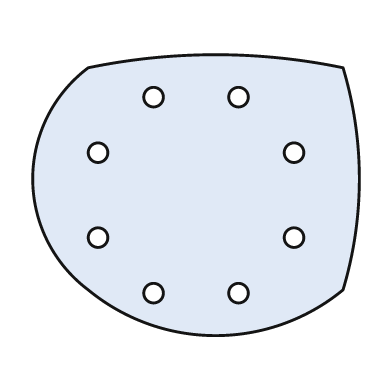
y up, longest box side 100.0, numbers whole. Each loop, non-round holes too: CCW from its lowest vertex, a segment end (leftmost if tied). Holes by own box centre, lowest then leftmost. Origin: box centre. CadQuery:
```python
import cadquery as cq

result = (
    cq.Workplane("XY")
    .moveTo(-33.0, -29.0)
    .threePointArc((6.0, -43.0), (45.0, -29.0))
    .threePointArc((50.0, 5.0), (45.0, 39.0))
    .threePointArc((6.0, 43.0), (-33.0, 39.0))
    .threePointArc((-50.0, 5.0), (-33.0, -29.0))
    .close()
    .moveTo(-13.0, -30.0)
    .circle(3.0)
    .moveTo(13.0, -30.0)
    .circle(3.0)
    .moveTo(-30.0, -13.0)
    .circle(3.0)
    .moveTo(30.0, -13.0)
    .circle(3.0)
    .moveTo(-30.0, 13.0)
    .circle(3.0)
    .moveTo(30.0, 13.0)
    .circle(3.0)
    .moveTo(-13.0, 30.0)
    .circle(3.0)
    .moveTo(13.0, 30.0)
    .circle(3.0)
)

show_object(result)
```